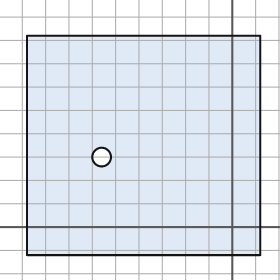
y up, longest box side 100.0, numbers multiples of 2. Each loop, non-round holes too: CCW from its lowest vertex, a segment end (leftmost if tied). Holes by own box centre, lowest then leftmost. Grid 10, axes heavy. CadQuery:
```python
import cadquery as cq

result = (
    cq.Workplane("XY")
    .moveTo(-88.0, -12.0)
    .lineTo(12.0, -12.0)
    .lineTo(12.0, 82.0)
    .lineTo(-88.0, 82.0)
    .close()
    .moveTo(-56.0, 30.0)
    .circle(4.0)
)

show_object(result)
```